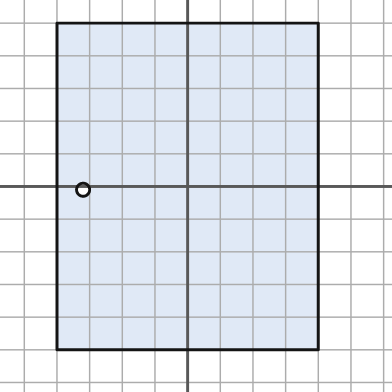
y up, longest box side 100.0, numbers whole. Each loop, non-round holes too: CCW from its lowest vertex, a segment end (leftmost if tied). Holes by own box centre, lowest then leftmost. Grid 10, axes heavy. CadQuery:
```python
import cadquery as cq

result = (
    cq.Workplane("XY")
    .moveTo(-40.0, -50.0)
    .lineTo(40.0, -50.0)
    .lineTo(40.0, 50.0)
    .lineTo(-40.0, 50.0)
    .close()
    .moveTo(-32.0, -1.0)
    .circle(2.0)
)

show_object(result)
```